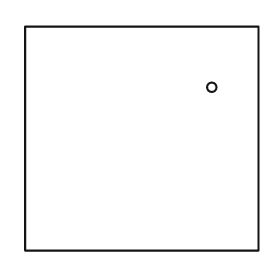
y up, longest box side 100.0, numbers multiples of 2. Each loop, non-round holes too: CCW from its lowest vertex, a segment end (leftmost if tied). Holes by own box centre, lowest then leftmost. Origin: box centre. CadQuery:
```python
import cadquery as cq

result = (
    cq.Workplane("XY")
    .moveTo(-50.0, -48.0)
    .lineTo(50.0, -48.0)
    .lineTo(50.0, 48.0)
    .lineTo(-50.0, 48.0)
    .close()
    .moveTo(30.0, 22.0)
    .circle(2.0)
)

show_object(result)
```